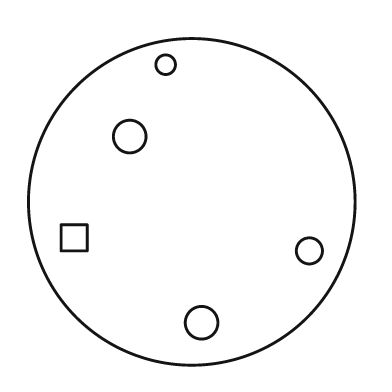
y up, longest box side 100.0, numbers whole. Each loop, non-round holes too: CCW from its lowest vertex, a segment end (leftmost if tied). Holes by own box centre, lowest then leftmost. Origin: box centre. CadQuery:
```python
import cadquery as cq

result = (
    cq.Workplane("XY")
    .moveTo(0.0, 0.0)
    .circle(50.0)
    .moveTo(3.0, -37.0)
    .circle(5.0)
    .moveTo(36.0, -15.0)
    .circle(4.0)
    .moveTo(-40.0, -15.0)
    .lineTo(-32.0, -15.0)
    .lineTo(-32.0, -7.0)
    .lineTo(-40.0, -7.0)
    .close()
    .moveTo(-19.0, 20.0)
    .circle(5.0)
    .moveTo(-8.0, 42.0)
    .circle(3.0)
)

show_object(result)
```